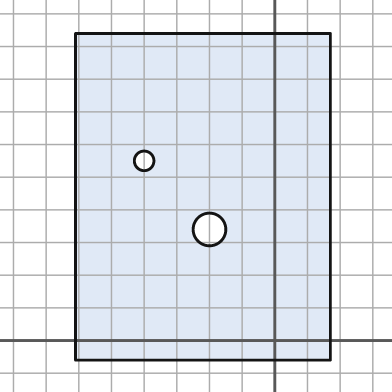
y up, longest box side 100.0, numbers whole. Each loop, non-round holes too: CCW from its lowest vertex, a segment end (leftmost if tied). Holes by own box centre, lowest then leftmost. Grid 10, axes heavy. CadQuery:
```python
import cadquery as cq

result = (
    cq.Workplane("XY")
    .moveTo(-61.0, -6.0)
    .lineTo(17.0, -6.0)
    .lineTo(17.0, 94.0)
    .lineTo(-61.0, 94.0)
    .close()
    .moveTo(-20.0, 34.0)
    .circle(5.0)
    .moveTo(-40.0, 55.0)
    .circle(3.0)
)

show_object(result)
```